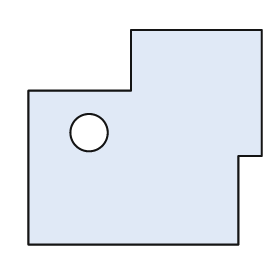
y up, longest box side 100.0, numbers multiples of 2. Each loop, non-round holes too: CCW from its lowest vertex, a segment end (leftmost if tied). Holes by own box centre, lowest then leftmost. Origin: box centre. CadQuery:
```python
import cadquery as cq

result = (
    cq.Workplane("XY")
    .moveTo(-50.0, -46.0)
    .lineTo(40.0, -46.0)
    .lineTo(40.0, -8.0)
    .lineTo(50.0, -8.0)
    .lineTo(50.0, 46.0)
    .lineTo(-6.0, 46.0)
    .lineTo(-6.0, 20.0)
    .lineTo(-50.0, 20.0)
    .close()
    .moveTo(-24.0, 2.0)
    .circle(8.0)
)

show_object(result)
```